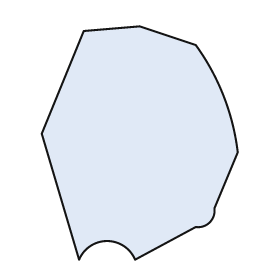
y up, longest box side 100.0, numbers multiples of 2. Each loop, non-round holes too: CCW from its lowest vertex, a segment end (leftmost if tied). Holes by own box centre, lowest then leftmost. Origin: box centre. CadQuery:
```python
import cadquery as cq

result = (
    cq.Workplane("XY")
    .moveTo(-26.0, -50.0)
    .threePointArc((-14.0, -42.0), (-2.0, -50.0))
    .lineTo(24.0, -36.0)
    .threePointArc((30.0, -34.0), (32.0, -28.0))
    .lineTo(42.0, -4.0)
    .threePointArc((36.0, 20.0), (24.0, 42.0))
    .lineTo(0.0, 50.0)
    .lineTo(-24.0, 48.0)
    .lineTo(-42.0, 4.0)
    .close()
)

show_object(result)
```